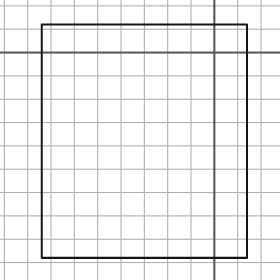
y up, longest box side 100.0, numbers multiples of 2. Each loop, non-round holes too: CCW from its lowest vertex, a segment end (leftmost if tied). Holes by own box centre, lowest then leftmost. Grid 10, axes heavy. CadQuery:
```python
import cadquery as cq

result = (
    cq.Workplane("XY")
    .moveTo(-74.0, -88.0)
    .lineTo(14.0, -88.0)
    .lineTo(14.0, 12.0)
    .lineTo(-74.0, 12.0)
    .close()
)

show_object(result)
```